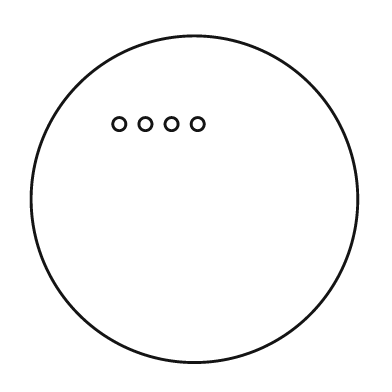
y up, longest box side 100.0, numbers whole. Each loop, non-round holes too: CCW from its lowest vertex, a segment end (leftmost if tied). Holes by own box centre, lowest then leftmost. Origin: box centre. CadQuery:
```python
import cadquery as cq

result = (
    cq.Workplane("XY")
    .moveTo(0.0, 0.0)
    .circle(50.0)
    .moveTo(-23.0, 23.0)
    .circle(2.0)
    .moveTo(-15.0, 23.0)
    .circle(2.0)
    .moveTo(-7.0, 23.0)
    .circle(2.0)
    .moveTo(1.0, 23.0)
    .circle(2.0)
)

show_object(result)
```